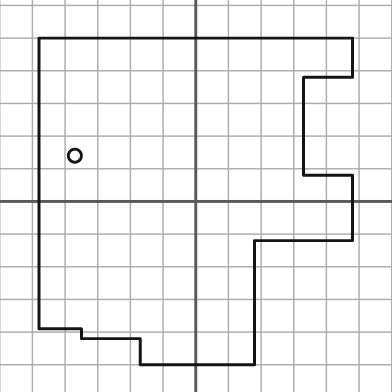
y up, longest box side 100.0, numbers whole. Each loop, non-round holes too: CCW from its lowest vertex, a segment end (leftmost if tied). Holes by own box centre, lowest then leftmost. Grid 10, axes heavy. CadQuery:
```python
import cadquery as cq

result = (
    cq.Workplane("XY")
    .moveTo(-17.0, -50.0)
    .lineTo(18.0, -50.0)
    .lineTo(18.0, -12.0)
    .lineTo(48.0, -12.0)
    .lineTo(48.0, 8.0)
    .lineTo(33.0, 8.0)
    .lineTo(33.0, 38.0)
    .lineTo(48.0, 38.0)
    .lineTo(48.0, 50.0)
    .lineTo(-48.0, 50.0)
    .lineTo(-48.0, -39.0)
    .lineTo(-35.0, -39.0)
    .lineTo(-35.0, -42.0)
    .lineTo(-17.0, -42.0)
    .close()
    .moveTo(-37.0, 14.0)
    .circle(2.0)
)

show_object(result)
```